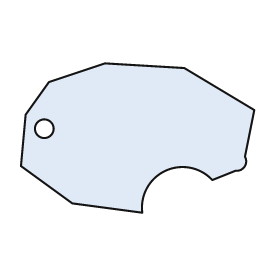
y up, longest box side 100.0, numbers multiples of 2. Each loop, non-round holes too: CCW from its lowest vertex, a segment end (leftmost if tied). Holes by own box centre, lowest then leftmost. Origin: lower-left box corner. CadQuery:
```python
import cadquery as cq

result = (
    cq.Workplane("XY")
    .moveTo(52.0, 0.0)
    .threePointArc((62.0, 18.0), (82.0, 14.0))
    .lineTo(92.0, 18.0)
    .threePointArc((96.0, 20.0), (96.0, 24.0))
    .lineTo(100.0, 44.0)
    .lineTo(70.0, 62.0)
    .lineTo(36.0, 64.0)
    .lineTo(12.0, 56.0)
    .lineTo(2.0, 42.0)
    .lineTo(0.0, 20.0)
    .lineTo(22.0, 4.0)
    .close()
    .moveTo(10.0, 36.0)
    .circle(4.0)
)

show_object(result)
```